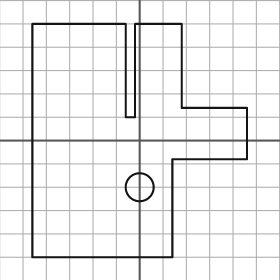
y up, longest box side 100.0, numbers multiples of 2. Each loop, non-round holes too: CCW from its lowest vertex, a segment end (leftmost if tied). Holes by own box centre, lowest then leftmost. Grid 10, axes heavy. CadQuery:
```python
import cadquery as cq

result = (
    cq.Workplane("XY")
    .moveTo(-46.0, -50.0)
    .lineTo(14.0, -50.0)
    .lineTo(14.0, -8.0)
    .lineTo(46.0, -8.0)
    .lineTo(46.0, 14.0)
    .lineTo(18.0, 14.0)
    .lineTo(18.0, 50.0)
    .lineTo(-2.0, 50.0)
    .lineTo(-2.0, 10.0)
    .lineTo(-6.0, 10.0)
    .lineTo(-6.0, 50.0)
    .lineTo(-46.0, 50.0)
    .close()
    .moveTo(0.0, -20.0)
    .circle(6.0)
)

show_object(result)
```